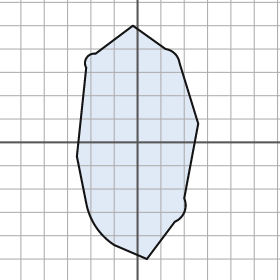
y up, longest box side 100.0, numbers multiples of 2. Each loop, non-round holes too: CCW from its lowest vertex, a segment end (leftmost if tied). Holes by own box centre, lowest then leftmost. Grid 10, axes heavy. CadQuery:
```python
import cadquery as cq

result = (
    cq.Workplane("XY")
    .moveTo(4.0, -50.0)
    .lineTo(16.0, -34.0)
    .threePointArc((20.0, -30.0), (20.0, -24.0))
    .lineTo(26.0, 8.0)
    .lineTo(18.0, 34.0)
    .threePointArc((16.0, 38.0), (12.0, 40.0))
    .lineTo(-2.0, 50.0)
    .lineTo(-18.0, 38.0)
    .threePointArc((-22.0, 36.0), (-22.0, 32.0))
    .lineTo(-26.0, -6.0)
    .lineTo(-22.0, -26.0)
    .threePointArc((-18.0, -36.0), (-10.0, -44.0))
    .close()
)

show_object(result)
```